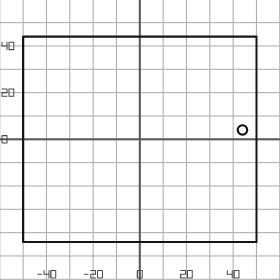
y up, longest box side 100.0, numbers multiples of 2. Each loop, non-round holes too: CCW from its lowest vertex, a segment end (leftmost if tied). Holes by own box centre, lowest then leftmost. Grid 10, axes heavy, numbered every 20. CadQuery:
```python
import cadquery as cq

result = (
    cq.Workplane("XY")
    .moveTo(-50.0, -44.0)
    .lineTo(50.0, -44.0)
    .lineTo(50.0, 44.0)
    .lineTo(-50.0, 44.0)
    .close()
    .moveTo(44.0, 4.0)
    .circle(2.0)
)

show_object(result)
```